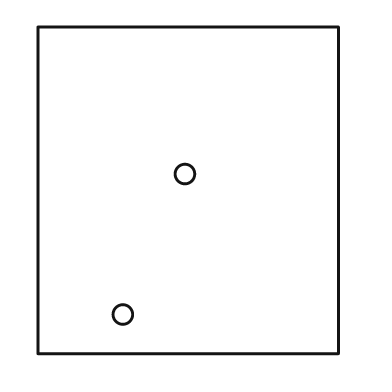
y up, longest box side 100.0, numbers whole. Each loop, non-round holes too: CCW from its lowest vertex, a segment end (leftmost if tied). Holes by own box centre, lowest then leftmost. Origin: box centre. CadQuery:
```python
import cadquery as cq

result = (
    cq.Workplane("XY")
    .moveTo(-46.0, -50.0)
    .lineTo(46.0, -50.0)
    .lineTo(46.0, 50.0)
    .lineTo(-46.0, 50.0)
    .close()
    .moveTo(-20.0, -38.0)
    .circle(3.0)
    .moveTo(-1.0, 5.0)
    .circle(3.0)
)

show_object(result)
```